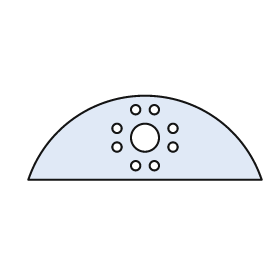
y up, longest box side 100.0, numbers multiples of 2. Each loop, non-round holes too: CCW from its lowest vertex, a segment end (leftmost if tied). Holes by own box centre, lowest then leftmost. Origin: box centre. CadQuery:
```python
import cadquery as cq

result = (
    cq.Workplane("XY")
    .moveTo(-50.0, -18.0)
    .lineTo(50.0, -18.0)
    .threePointArc((0.0, 18.0), (-50.0, -18.0))
    .close()
    .moveTo(-4.0, -12.0)
    .circle(2.0)
    .moveTo(4.0, -12.0)
    .circle(2.0)
    .moveTo(-12.0, -4.0)
    .circle(2.0)
    .moveTo(12.0, -4.0)
    .circle(2.0)
    .moveTo(0.0, 0.0)
    .circle(6.0)
    .moveTo(-12.0, 4.0)
    .circle(2.0)
    .moveTo(12.0, 4.0)
    .circle(2.0)
    .moveTo(-4.0, 12.0)
    .circle(2.0)
    .moveTo(4.0, 12.0)
    .circle(2.0)
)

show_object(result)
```